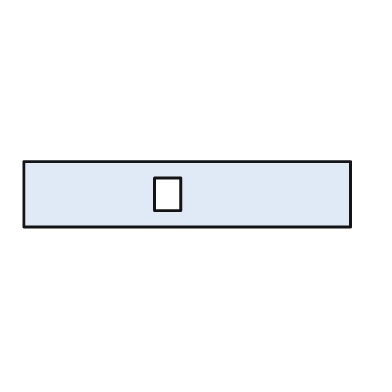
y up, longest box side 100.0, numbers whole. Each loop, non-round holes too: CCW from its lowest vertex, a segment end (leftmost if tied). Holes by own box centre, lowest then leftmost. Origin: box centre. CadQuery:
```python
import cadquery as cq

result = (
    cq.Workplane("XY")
    .moveTo(-50.0, -10.0)
    .lineTo(50.0, -10.0)
    .lineTo(50.0, 10.0)
    .lineTo(-50.0, 10.0)
    .close()
    .moveTo(-10.0, -5.0)
    .lineTo(-2.0, -5.0)
    .lineTo(-2.0, 5.0)
    .lineTo(-10.0, 5.0)
    .close()
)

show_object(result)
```